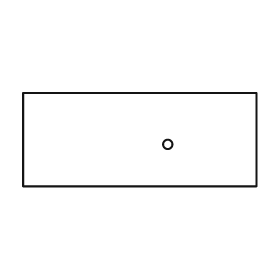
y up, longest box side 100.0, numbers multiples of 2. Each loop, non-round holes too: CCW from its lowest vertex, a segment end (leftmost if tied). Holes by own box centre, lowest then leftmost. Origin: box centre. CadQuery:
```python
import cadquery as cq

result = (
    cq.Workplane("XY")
    .moveTo(-50.0, -20.0)
    .lineTo(50.0, -20.0)
    .lineTo(50.0, 20.0)
    .lineTo(-50.0, 20.0)
    .close()
    .moveTo(12.0, -2.0)
    .circle(2.0)
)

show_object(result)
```